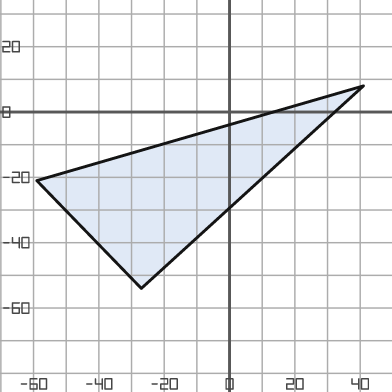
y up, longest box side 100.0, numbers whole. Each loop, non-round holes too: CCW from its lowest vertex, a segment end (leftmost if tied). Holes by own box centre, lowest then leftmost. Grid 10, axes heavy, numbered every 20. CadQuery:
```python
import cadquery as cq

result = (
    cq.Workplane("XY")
    .moveTo(-27.0, -54.0)
    .lineTo(41.0, 8.0)
    .lineTo(-59.0, -21.0)
    .close()
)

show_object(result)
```